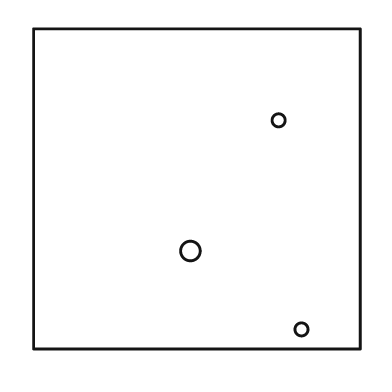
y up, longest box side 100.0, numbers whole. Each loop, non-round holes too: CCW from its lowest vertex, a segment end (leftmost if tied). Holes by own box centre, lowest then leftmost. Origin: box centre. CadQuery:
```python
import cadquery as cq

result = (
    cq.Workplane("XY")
    .moveTo(-50.0, -49.0)
    .lineTo(50.0, -49.0)
    .lineTo(50.0, 49.0)
    .lineTo(-50.0, 49.0)
    .close()
    .moveTo(32.0, -43.0)
    .circle(2.0)
    .moveTo(-2.0, -19.0)
    .circle(3.0)
    .moveTo(25.0, 21.0)
    .circle(2.0)
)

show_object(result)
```